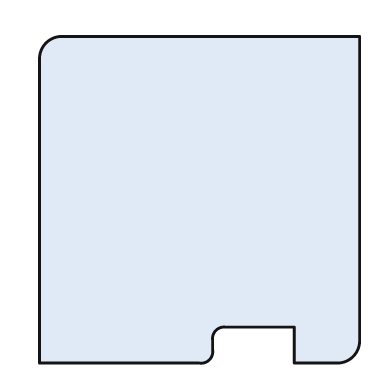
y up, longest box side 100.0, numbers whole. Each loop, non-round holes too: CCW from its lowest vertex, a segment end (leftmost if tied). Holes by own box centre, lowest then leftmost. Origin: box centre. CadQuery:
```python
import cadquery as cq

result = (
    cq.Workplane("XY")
    .moveTo(-49.0, -50.0)
    .lineTo(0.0, -50.0)
    .threePointArc((3.0, -49.0), (4.0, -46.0))
    .lineTo(4.0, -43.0)
    .threePointArc((5.0, -40.0), (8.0, -39.0))
    .lineTo(29.0, -39.0)
    .lineTo(29.0, -50.0)
    .lineTo(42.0, -50.0)
    .threePointArc((47.0, -48.0), (49.0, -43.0))
    .lineTo(49.0, 50.0)
    .lineTo(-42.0, 50.0)
    .threePointArc((-47.0, 48.0), (-49.0, 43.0))
    .close()
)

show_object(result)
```